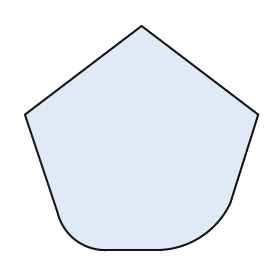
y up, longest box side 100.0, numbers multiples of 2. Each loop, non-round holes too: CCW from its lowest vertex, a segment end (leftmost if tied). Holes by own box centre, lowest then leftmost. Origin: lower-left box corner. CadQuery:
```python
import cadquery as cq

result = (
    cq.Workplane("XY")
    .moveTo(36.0, 0.0)
    .lineTo(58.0, 0.0)
    .threePointArc((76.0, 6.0), (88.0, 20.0))
    .lineTo(100.0, 58.0)
    .lineTo(50.0, 96.0)
    .lineTo(0.0, 58.0)
    .lineTo(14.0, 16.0)
    .threePointArc((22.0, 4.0), (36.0, 0.0))
    .close()
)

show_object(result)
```